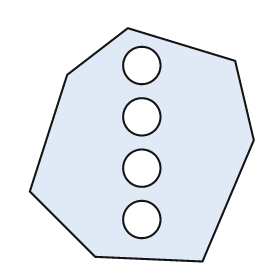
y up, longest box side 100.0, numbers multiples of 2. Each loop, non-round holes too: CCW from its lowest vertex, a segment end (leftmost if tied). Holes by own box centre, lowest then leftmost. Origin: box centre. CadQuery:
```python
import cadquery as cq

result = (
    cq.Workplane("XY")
    .moveTo(26.0, -50.0)
    .lineTo(48.0, 2.0)
    .lineTo(40.0, 36.0)
    .lineTo(-6.0, 50.0)
    .lineTo(-32.0, 30.0)
    .lineTo(-48.0, -20.0)
    .lineTo(-20.0, -48.0)
    .close()
    .moveTo(0.0, -32.0)
    .circle(8.0)
    .moveTo(0.0, -10.0)
    .circle(8.0)
    .moveTo(0.0, 12.0)
    .circle(8.0)
    .moveTo(0.0, 34.0)
    .circle(8.0)
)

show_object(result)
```